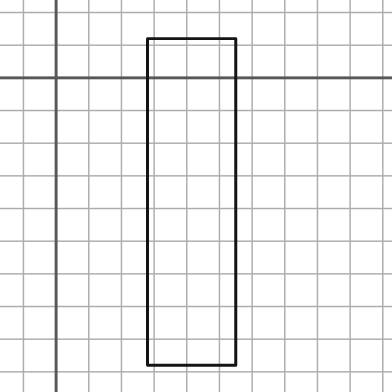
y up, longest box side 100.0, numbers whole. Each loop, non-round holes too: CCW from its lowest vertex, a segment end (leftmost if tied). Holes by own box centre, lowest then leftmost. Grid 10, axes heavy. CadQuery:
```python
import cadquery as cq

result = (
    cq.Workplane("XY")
    .moveTo(28.0, -88.0)
    .lineTo(55.0, -88.0)
    .lineTo(55.0, 12.0)
    .lineTo(28.0, 12.0)
    .close()
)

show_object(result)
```